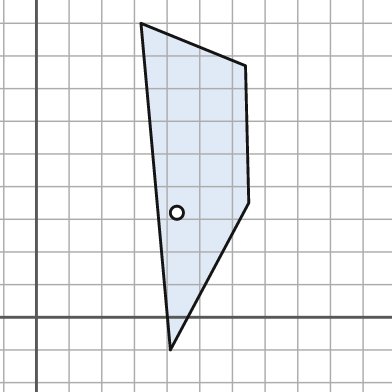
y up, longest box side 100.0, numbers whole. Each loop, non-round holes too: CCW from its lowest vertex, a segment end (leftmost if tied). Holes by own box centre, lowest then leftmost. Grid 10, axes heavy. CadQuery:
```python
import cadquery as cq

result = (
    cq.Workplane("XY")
    .moveTo(41.0, -10.0)
    .lineTo(65.0, 35.0)
    .lineTo(64.0, 77.0)
    .lineTo(32.0, 90.0)
    .close()
    .moveTo(43.0, 32.0)
    .circle(2.0)
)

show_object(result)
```